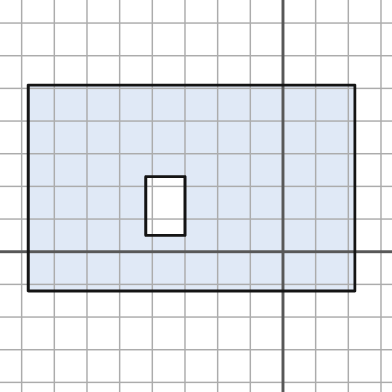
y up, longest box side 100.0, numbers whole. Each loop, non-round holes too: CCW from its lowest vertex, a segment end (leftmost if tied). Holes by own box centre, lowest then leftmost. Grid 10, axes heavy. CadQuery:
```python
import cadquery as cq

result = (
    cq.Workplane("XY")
    .moveTo(-78.0, -12.0)
    .lineTo(22.0, -12.0)
    .lineTo(22.0, 51.0)
    .lineTo(-78.0, 51.0)
    .close()
    .moveTo(-42.0, 5.0)
    .lineTo(-30.0, 5.0)
    .lineTo(-30.0, 23.0)
    .lineTo(-42.0, 23.0)
    .close()
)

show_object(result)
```